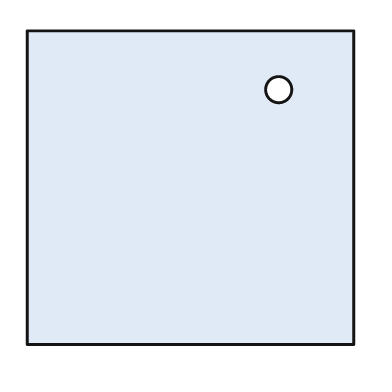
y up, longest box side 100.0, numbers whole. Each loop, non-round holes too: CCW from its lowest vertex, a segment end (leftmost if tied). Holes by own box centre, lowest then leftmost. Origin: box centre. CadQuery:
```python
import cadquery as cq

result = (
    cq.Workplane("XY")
    .moveTo(-50.0, -48.0)
    .lineTo(50.0, -48.0)
    .lineTo(50.0, 48.0)
    .lineTo(-50.0, 48.0)
    .close()
    .moveTo(27.0, 30.0)
    .circle(4.0)
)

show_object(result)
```